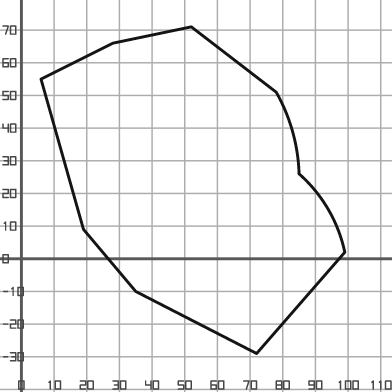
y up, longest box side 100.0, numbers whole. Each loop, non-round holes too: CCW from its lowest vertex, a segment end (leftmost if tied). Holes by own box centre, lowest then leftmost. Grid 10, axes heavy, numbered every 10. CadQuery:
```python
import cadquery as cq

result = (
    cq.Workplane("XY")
    .moveTo(72.0, -29.0)
    .lineTo(99.0, 2.0)
    .threePointArc((94.0, 15.0), (85.0, 26.0))
    .threePointArc((83.0, 39.0), (78.0, 51.0))
    .lineTo(52.0, 71.0)
    .lineTo(28.0, 66.0)
    .lineTo(6.0, 55.0)
    .lineTo(19.0, 9.0)
    .lineTo(35.0, -10.0)
    .close()
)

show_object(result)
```